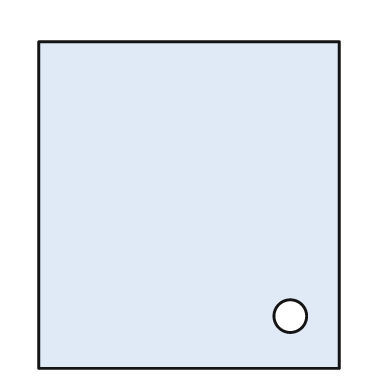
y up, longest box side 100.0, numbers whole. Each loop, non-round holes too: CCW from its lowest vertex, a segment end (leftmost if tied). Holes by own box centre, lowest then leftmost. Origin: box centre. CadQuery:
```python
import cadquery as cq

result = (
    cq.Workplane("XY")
    .moveTo(-46.0, -50.0)
    .lineTo(46.0, -50.0)
    .lineTo(46.0, 50.0)
    .lineTo(-46.0, 50.0)
    .close()
    .moveTo(31.0, -34.0)
    .circle(5.0)
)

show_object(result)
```